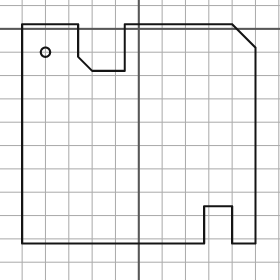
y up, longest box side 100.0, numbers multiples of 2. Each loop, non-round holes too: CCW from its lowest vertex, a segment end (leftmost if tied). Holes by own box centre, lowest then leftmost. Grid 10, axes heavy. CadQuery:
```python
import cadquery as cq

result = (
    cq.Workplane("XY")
    .moveTo(-50.0, -92.0)
    .lineTo(28.0, -92.0)
    .lineTo(28.0, -76.0)
    .lineTo(40.0, -76.0)
    .lineTo(40.0, -92.0)
    .lineTo(50.0, -92.0)
    .lineTo(50.0, -8.0)
    .lineTo(40.0, 2.0)
    .lineTo(-6.0, 2.0)
    .lineTo(-6.0, -18.0)
    .lineTo(-20.0, -18.0)
    .lineTo(-26.0, -12.0)
    .lineTo(-26.0, 2.0)
    .lineTo(-50.0, 2.0)
    .close()
    .moveTo(-40.0, -10.0)
    .circle(2.0)
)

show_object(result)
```